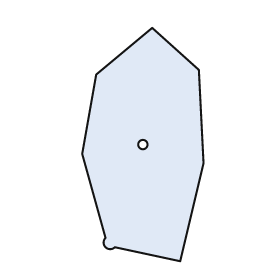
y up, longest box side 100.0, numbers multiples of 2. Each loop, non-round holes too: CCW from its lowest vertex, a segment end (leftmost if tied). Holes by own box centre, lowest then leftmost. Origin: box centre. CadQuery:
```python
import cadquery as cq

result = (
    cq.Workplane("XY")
    .moveTo(16.0, -50.0)
    .lineTo(26.0, -8.0)
    .lineTo(24.0, 32.0)
    .lineTo(4.0, 50.0)
    .lineTo(-20.0, 30.0)
    .lineTo(-26.0, -4.0)
    .lineTo(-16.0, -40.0)
    .threePointArc((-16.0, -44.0), (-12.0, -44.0))
    .close()
    .moveTo(0.0, 0.0)
    .circle(2.0)
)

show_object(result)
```